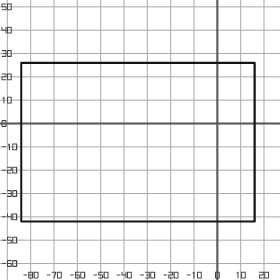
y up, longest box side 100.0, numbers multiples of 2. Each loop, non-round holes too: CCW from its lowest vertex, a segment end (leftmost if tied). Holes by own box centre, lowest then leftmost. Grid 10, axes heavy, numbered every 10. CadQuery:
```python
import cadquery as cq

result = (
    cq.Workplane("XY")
    .moveTo(-84.0, -42.0)
    .lineTo(16.0, -42.0)
    .lineTo(16.0, 26.0)
    .lineTo(-84.0, 26.0)
    .close()
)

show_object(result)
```